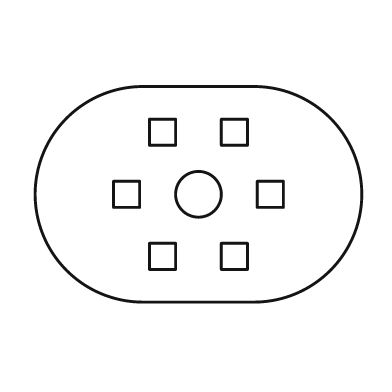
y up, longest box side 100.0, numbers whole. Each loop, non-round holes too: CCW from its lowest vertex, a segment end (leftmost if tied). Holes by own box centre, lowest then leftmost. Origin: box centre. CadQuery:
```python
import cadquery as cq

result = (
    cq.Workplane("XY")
    .moveTo(-17.0, -33.0)
    .lineTo(17.0, -33.0)
    .threePointArc((50.0, 0.0), (17.0, 33.0))
    .lineTo(-17.0, 33.0)
    .threePointArc((-50.0, 0.0), (-17.0, -33.0))
    .close()
    .moveTo(-15.0, -23.0)
    .lineTo(-7.0, -23.0)
    .lineTo(-7.0, -15.0)
    .lineTo(-15.0, -15.0)
    .close()
    .moveTo(7.0, -23.0)
    .lineTo(15.0, -23.0)
    .lineTo(15.0, -15.0)
    .lineTo(7.0, -15.0)
    .close()
    .moveTo(-26.0, -4.0)
    .lineTo(-18.0, -4.0)
    .lineTo(-18.0, 4.0)
    .lineTo(-26.0, 4.0)
    .close()
    .moveTo(0.0, 0.0)
    .circle(7.0)
    .moveTo(18.0, -4.0)
    .lineTo(26.0, -4.0)
    .lineTo(26.0, 4.0)
    .lineTo(18.0, 4.0)
    .close()
    .moveTo(-15.0, 15.0)
    .lineTo(-7.0, 15.0)
    .lineTo(-7.0, 23.0)
    .lineTo(-15.0, 23.0)
    .close()
    .moveTo(7.0, 15.0)
    .lineTo(15.0, 15.0)
    .lineTo(15.0, 23.0)
    .lineTo(7.0, 23.0)
    .close()
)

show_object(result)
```